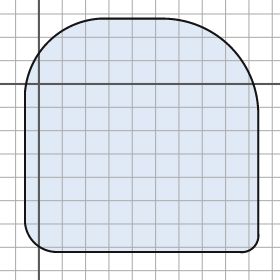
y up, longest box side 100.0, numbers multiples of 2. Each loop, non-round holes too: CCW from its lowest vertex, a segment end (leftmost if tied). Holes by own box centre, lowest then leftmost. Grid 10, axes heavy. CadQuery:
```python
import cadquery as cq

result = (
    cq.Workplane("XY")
    .moveTo(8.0, -72.0)
    .lineTo(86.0, -72.0)
    .threePointArc((92.0, -70.0), (94.0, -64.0))
    .lineTo(94.0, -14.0)
    .threePointArc((82.0, 16.0), (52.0, 28.0))
    .lineTo(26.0, 28.0)
    .threePointArc((4.0, 18.0), (-6.0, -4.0))
    .lineTo(-6.0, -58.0)
    .threePointArc((-2.0, -68.0), (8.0, -72.0))
    .close()
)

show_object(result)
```